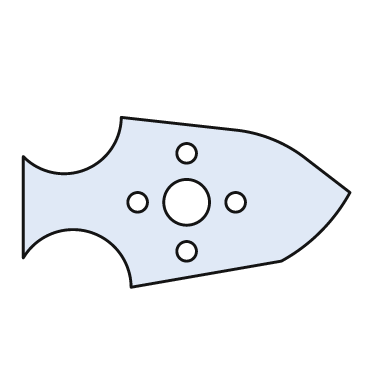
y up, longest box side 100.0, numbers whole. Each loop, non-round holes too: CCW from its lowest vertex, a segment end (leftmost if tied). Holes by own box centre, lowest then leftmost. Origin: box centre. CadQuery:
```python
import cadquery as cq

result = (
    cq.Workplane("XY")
    .moveTo(-17.0, -26.0)
    .lineTo(29.0, -18.0)
    .threePointArc((41.0, -9.0), (50.0, 3.0))
    .lineTo(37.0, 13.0)
    .threePointArc((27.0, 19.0), (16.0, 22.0))
    .lineTo(-20.0, 26.0)
    .threePointArc((-31.0, 10.0), (-50.0, 14.0))
    .lineTo(-50.0, -17.0)
    .threePointArc((-30.0, -9.0), (-17.0, -26.0))
    .close()
    .moveTo(0.0, -15.0)
    .circle(3.0)
    .moveTo(-15.0, 0.0)
    .circle(3.0)
    .moveTo(0.0, 0.0)
    .circle(7.0)
    .moveTo(15.0, 0.0)
    .circle(3.0)
    .moveTo(0.0, 15.0)
    .circle(3.0)
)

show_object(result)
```